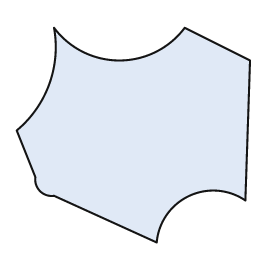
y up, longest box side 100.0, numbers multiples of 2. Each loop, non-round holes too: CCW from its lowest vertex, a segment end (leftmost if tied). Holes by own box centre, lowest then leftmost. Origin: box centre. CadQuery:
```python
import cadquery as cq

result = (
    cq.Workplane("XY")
    .moveTo(10.0, -46.0)
    .threePointArc((24.0, -26.0), (48.0, -28.0))
    .lineTo(50.0, 32.0)
    .lineTo(22.0, 46.0)
    .threePointArc((-6.0, 32.0), (-34.0, 46.0))
    .threePointArc((-36.0, 22.0), (-50.0, 2.0))
    .lineTo(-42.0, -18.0)
    .threePointArc((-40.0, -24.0), (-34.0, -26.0))
    .close()
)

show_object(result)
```